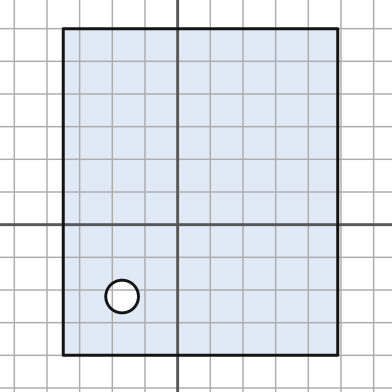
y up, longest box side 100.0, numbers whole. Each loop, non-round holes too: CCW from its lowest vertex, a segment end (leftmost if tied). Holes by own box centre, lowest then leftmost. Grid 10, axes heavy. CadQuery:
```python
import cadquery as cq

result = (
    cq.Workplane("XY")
    .moveTo(-35.0, -40.0)
    .lineTo(49.0, -40.0)
    .lineTo(49.0, 60.0)
    .lineTo(-35.0, 60.0)
    .close()
    .moveTo(-17.0, -22.0)
    .circle(5.0)
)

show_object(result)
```